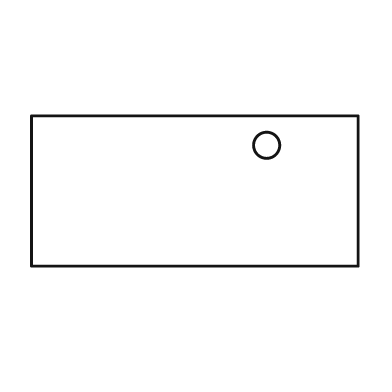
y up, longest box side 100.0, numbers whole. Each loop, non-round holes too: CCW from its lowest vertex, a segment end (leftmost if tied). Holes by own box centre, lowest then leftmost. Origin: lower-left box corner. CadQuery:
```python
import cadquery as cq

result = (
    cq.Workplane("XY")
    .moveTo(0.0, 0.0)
    .lineTo(100.0, 0.0)
    .lineTo(100.0, 46.0)
    .lineTo(0.0, 46.0)
    .close()
    .moveTo(72.0, 37.0)
    .circle(4.0)
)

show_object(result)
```